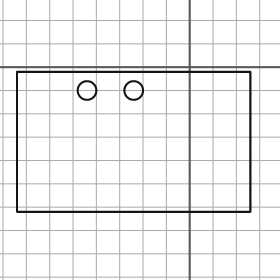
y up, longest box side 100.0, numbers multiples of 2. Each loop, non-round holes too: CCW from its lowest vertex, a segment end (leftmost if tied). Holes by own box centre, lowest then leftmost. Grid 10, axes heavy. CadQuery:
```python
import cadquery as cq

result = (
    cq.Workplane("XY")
    .moveTo(-74.0, -62.0)
    .lineTo(26.0, -62.0)
    .lineTo(26.0, -2.0)
    .lineTo(-74.0, -2.0)
    .close()
    .moveTo(-44.0, -10.0)
    .circle(4.0)
    .moveTo(-24.0, -10.0)
    .circle(4.0)
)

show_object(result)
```